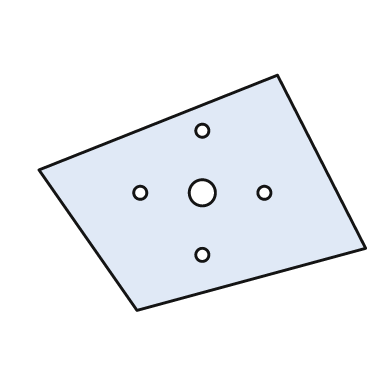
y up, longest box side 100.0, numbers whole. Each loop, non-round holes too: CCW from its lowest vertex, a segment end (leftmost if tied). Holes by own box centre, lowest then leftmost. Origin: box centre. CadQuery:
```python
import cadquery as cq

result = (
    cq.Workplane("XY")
    .moveTo(-20.0, -36.0)
    .lineTo(50.0, -17.0)
    .lineTo(23.0, 36.0)
    .lineTo(-50.0, 7.0)
    .close()
    .moveTo(0.0, -19.0)
    .circle(2.0)
    .moveTo(-19.0, 0.0)
    .circle(2.0)
    .moveTo(0.0, 0.0)
    .circle(4.0)
    .moveTo(19.0, 0.0)
    .circle(2.0)
    .moveTo(0.0, 19.0)
    .circle(2.0)
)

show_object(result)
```